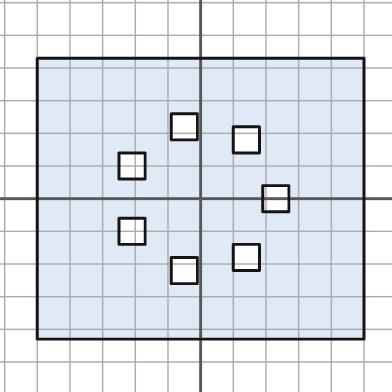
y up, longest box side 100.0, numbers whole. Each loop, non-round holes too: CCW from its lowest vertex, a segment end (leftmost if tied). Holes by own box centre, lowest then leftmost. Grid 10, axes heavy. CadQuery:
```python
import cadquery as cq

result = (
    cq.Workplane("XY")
    .moveTo(-50.0, -43.0)
    .lineTo(50.0, -43.0)
    .lineTo(50.0, 43.0)
    .lineTo(-50.0, 43.0)
    .close()
    .moveTo(-9.0, -26.0)
    .lineTo(-1.0, -26.0)
    .lineTo(-1.0, -18.0)
    .lineTo(-9.0, -18.0)
    .close()
    .moveTo(10.0, -22.0)
    .lineTo(18.0, -22.0)
    .lineTo(18.0, -14.0)
    .lineTo(10.0, -14.0)
    .close()
    .moveTo(-25.0, -14.0)
    .lineTo(-17.0, -14.0)
    .lineTo(-17.0, -6.0)
    .lineTo(-25.0, -6.0)
    .close()
    .moveTo(19.0, -4.0)
    .lineTo(27.0, -4.0)
    .lineTo(27.0, 4.0)
    .lineTo(19.0, 4.0)
    .close()
    .moveTo(-25.0, 6.0)
    .lineTo(-17.0, 6.0)
    .lineTo(-17.0, 14.0)
    .lineTo(-25.0, 14.0)
    .close()
    .moveTo(10.0, 14.0)
    .lineTo(18.0, 14.0)
    .lineTo(18.0, 22.0)
    .lineTo(10.0, 22.0)
    .close()
    .moveTo(-9.0, 18.0)
    .lineTo(-1.0, 18.0)
    .lineTo(-1.0, 26.0)
    .lineTo(-9.0, 26.0)
    .close()
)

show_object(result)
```